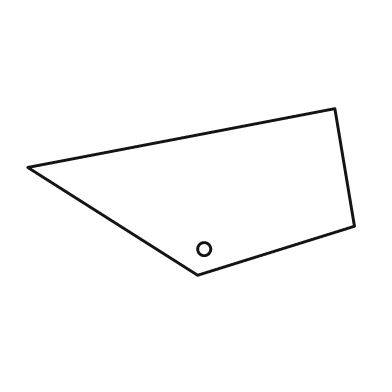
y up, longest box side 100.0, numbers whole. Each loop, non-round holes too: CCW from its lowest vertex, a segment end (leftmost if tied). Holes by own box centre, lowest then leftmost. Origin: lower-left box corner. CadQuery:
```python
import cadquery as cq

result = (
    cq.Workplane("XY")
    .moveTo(52.0, 0.0)
    .lineTo(100.0, 15.0)
    .lineTo(94.0, 51.0)
    .lineTo(0.0, 33.0)
    .close()
    .moveTo(54.0, 8.0)
    .circle(2.0)
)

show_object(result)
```